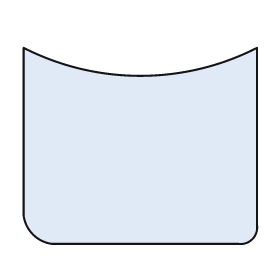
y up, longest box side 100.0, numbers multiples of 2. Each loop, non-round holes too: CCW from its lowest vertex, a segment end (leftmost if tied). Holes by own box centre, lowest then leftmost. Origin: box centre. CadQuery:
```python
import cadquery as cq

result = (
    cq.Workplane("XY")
    .moveTo(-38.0, -42.0)
    .lineTo(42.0, -42.0)
    .threePointArc((48.0, -40.0), (50.0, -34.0))
    .lineTo(50.0, 42.0)
    .threePointArc((0.0, 30.0), (-50.0, 42.0))
    .lineTo(-50.0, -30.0)
    .threePointArc((-46.0, -38.0), (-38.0, -42.0))
    .close()
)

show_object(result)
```